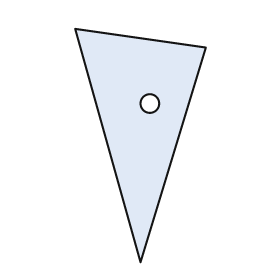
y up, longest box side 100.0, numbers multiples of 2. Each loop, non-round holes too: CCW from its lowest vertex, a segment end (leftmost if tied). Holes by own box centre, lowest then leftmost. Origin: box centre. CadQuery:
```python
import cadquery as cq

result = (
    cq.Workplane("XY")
    .moveTo(0.0, -50.0)
    .lineTo(28.0, 42.0)
    .lineTo(-28.0, 50.0)
    .close()
    .moveTo(4.0, 18.0)
    .circle(4.0)
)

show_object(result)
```